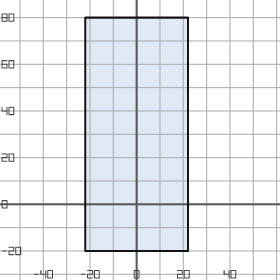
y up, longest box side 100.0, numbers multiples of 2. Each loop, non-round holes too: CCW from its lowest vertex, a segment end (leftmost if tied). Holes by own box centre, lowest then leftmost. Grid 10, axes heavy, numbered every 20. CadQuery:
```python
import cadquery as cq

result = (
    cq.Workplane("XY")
    .moveTo(-22.0, -20.0)
    .lineTo(22.0, -20.0)
    .lineTo(22.0, 80.0)
    .lineTo(-22.0, 80.0)
    .close()
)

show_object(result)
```